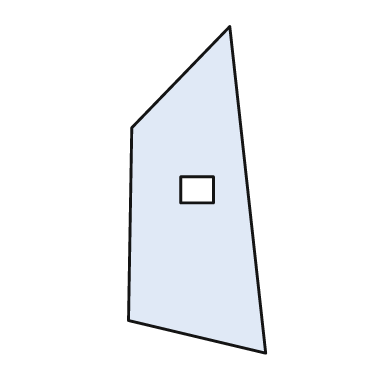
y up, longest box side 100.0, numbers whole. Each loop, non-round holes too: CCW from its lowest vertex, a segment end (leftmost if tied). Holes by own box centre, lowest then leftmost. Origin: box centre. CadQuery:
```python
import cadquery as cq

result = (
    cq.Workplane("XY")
    .moveTo(21.0, -50.0)
    .lineTo(10.0, 50.0)
    .lineTo(-20.0, 19.0)
    .lineTo(-21.0, -40.0)
    .close()
    .moveTo(-5.0, -4.0)
    .lineTo(5.0, -4.0)
    .lineTo(5.0, 4.0)
    .lineTo(-5.0, 4.0)
    .close()
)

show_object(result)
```